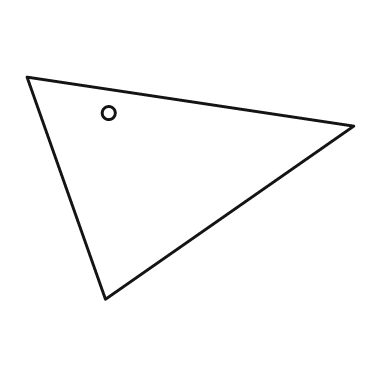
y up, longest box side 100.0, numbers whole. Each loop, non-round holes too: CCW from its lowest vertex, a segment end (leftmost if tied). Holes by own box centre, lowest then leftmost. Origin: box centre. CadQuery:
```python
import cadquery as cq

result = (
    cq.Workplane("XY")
    .moveTo(-26.0, -34.0)
    .lineTo(50.0, 19.0)
    .lineTo(-50.0, 34.0)
    .close()
    .moveTo(-25.0, 23.0)
    .circle(2.0)
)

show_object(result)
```